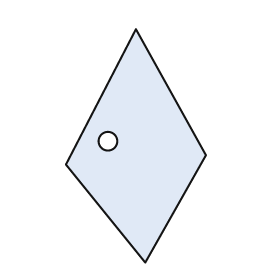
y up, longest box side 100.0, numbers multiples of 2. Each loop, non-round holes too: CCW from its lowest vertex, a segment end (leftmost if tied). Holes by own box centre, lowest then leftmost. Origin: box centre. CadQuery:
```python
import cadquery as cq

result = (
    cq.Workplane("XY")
    .moveTo(4.0, -50.0)
    .lineTo(30.0, -4.0)
    .lineTo(0.0, 50.0)
    .lineTo(-30.0, -8.0)
    .close()
    .moveTo(-12.0, 2.0)
    .circle(4.0)
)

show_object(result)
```